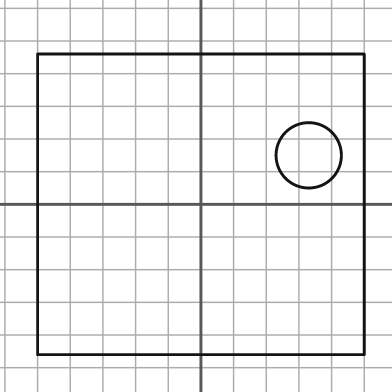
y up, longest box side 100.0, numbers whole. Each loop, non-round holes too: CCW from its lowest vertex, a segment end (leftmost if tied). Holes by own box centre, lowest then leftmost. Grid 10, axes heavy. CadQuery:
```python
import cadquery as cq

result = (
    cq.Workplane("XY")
    .moveTo(-50.0, -46.0)
    .lineTo(50.0, -46.0)
    .lineTo(50.0, 46.0)
    .lineTo(-50.0, 46.0)
    .close()
    .moveTo(33.0, 15.0)
    .circle(10.0)
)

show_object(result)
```